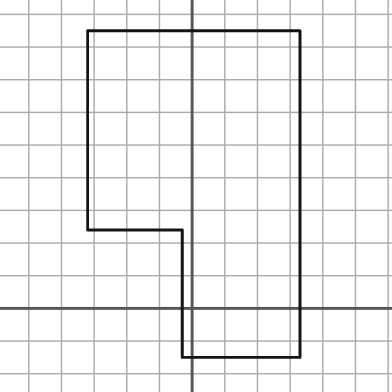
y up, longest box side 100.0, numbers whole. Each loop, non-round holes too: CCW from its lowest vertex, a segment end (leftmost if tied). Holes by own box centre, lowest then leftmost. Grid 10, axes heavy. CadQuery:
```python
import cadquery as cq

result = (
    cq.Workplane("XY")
    .moveTo(-3.0, -15.0)
    .lineTo(33.0, -15.0)
    .lineTo(33.0, 85.0)
    .lineTo(-32.0, 85.0)
    .lineTo(-32.0, 24.0)
    .lineTo(-3.0, 24.0)
    .close()
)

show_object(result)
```